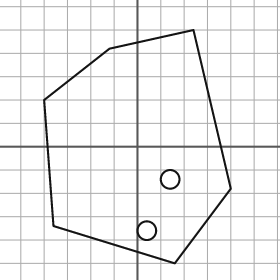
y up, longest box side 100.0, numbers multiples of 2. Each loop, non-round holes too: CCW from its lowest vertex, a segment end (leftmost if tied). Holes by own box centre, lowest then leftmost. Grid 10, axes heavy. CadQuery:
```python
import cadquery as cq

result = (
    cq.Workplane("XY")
    .moveTo(16.0, -50.0)
    .lineTo(40.0, -18.0)
    .lineTo(24.0, 50.0)
    .lineTo(-12.0, 42.0)
    .lineTo(-40.0, 20.0)
    .lineTo(-36.0, -34.0)
    .close()
    .moveTo(4.0, -36.0)
    .circle(4.0)
    .moveTo(14.0, -14.0)
    .circle(4.0)
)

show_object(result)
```